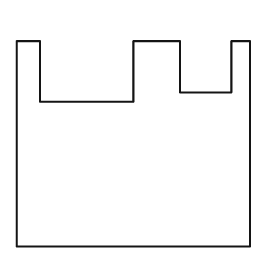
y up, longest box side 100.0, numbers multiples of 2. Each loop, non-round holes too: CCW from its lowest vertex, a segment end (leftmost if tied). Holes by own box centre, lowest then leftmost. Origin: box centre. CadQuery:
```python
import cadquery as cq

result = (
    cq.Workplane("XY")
    .moveTo(-50.0, -44.0)
    .lineTo(50.0, -44.0)
    .lineTo(50.0, 44.0)
    .lineTo(42.0, 44.0)
    .lineTo(42.0, 22.0)
    .lineTo(20.0, 22.0)
    .lineTo(20.0, 44.0)
    .lineTo(0.0, 44.0)
    .lineTo(0.0, 18.0)
    .lineTo(-40.0, 18.0)
    .lineTo(-40.0, 44.0)
    .lineTo(-50.0, 44.0)
    .close()
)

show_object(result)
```